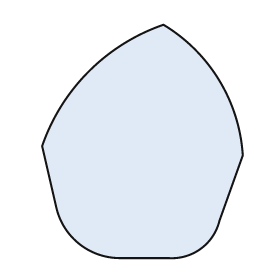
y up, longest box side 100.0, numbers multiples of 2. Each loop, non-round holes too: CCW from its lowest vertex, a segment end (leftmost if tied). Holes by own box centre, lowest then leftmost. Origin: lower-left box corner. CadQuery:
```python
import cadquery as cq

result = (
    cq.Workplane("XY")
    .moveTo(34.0, 0.0)
    .lineTo(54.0, 0.0)
    .threePointArc((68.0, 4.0), (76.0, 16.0))
    .lineTo(86.0, 44.0)
    .threePointArc((76.0, 76.0), (52.0, 100.0))
    .threePointArc((20.0, 80.0), (0.0, 48.0))
    .lineTo(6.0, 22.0)
    .threePointArc((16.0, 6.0), (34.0, 0.0))
    .close()
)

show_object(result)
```